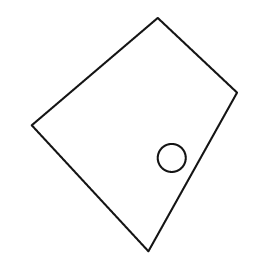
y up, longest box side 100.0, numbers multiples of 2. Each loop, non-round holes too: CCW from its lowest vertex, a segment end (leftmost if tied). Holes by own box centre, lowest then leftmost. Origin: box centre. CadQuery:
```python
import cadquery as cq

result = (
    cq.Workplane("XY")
    .moveTo(6.0, -50.0)
    .lineTo(44.0, 18.0)
    .lineTo(10.0, 50.0)
    .lineTo(-44.0, 4.0)
    .close()
    .moveTo(16.0, -10.0)
    .circle(6.0)
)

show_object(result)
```